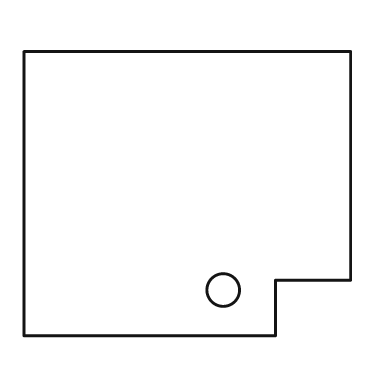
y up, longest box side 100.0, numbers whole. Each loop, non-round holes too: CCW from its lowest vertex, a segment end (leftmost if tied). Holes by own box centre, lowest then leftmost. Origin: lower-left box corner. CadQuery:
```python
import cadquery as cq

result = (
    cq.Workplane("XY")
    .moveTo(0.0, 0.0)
    .lineTo(77.0, 0.0)
    .lineTo(77.0, 17.0)
    .lineTo(100.0, 17.0)
    .lineTo(100.0, 87.0)
    .lineTo(0.0, 87.0)
    .close()
    .moveTo(61.0, 14.0)
    .circle(5.0)
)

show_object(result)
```